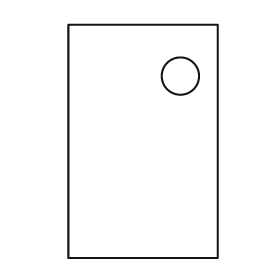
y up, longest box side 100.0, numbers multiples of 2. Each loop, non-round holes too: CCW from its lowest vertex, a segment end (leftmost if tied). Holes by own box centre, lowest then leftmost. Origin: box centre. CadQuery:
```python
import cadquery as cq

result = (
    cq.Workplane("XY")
    .moveTo(-32.0, -50.0)
    .lineTo(32.0, -50.0)
    .lineTo(32.0, 50.0)
    .lineTo(-32.0, 50.0)
    .close()
    .moveTo(16.0, 28.0)
    .circle(8.0)
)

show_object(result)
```